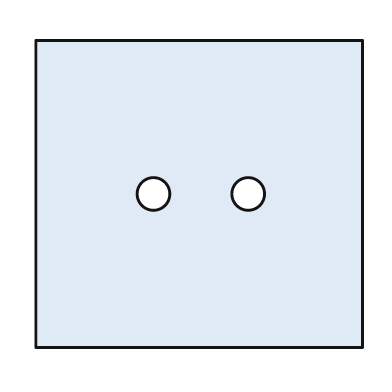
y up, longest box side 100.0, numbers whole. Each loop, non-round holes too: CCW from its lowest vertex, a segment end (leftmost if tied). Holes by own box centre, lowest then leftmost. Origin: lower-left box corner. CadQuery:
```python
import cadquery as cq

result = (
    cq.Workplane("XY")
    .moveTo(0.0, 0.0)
    .lineTo(100.0, 0.0)
    .lineTo(100.0, 94.0)
    .lineTo(0.0, 94.0)
    .close()
    .moveTo(36.0, 47.0)
    .circle(5.0)
    .moveTo(65.0, 47.0)
    .circle(5.0)
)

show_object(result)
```